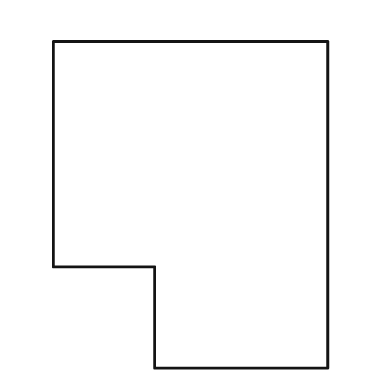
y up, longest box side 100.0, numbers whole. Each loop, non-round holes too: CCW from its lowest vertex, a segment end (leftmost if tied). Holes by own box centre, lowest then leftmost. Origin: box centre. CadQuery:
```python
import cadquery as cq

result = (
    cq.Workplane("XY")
    .moveTo(-11.0, -50.0)
    .lineTo(42.0, -50.0)
    .lineTo(42.0, 50.0)
    .lineTo(-42.0, 50.0)
    .lineTo(-42.0, -19.0)
    .lineTo(-11.0, -19.0)
    .close()
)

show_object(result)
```